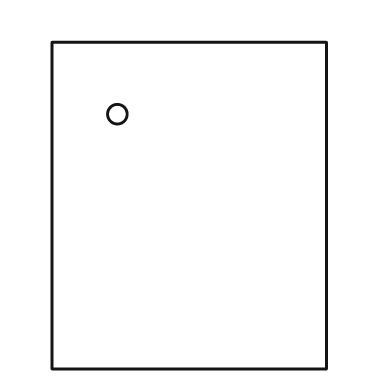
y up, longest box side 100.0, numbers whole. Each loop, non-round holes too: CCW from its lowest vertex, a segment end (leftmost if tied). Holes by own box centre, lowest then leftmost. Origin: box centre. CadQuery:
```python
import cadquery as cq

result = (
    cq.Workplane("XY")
    .moveTo(-42.0, -50.0)
    .lineTo(42.0, -50.0)
    .lineTo(42.0, 50.0)
    .lineTo(-42.0, 50.0)
    .close()
    .moveTo(-22.0, 28.0)
    .circle(3.0)
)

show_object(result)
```